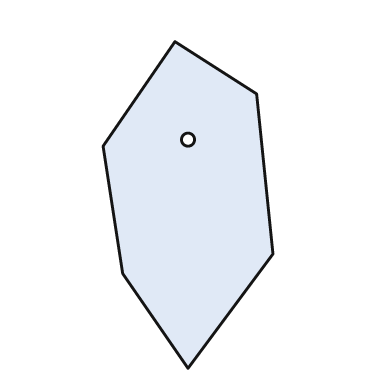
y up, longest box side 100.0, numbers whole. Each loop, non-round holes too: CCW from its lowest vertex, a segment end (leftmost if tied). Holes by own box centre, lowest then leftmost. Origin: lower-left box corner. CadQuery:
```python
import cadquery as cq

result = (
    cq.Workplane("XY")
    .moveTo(26.0, 0.0)
    .lineTo(52.0, 35.0)
    .lineTo(47.0, 84.0)
    .lineTo(22.0, 100.0)
    .lineTo(0.0, 68.0)
    .lineTo(6.0, 29.0)
    .close()
    .moveTo(26.0, 70.0)
    .circle(2.0)
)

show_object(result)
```